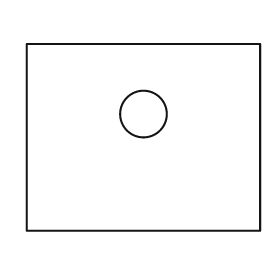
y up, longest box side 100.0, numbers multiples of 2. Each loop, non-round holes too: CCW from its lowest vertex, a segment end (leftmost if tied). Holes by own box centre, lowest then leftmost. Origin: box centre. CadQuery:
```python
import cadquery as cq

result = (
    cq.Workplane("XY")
    .moveTo(-50.0, -40.0)
    .lineTo(50.0, -40.0)
    .lineTo(50.0, 40.0)
    .lineTo(-50.0, 40.0)
    .close()
    .moveTo(0.0, 10.0)
    .circle(10.0)
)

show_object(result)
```